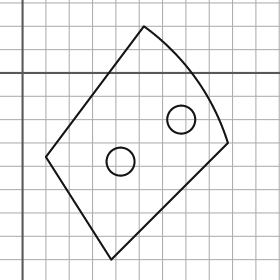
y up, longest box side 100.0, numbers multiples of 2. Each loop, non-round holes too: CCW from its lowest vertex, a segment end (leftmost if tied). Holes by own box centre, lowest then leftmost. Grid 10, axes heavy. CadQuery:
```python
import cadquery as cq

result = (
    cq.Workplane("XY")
    .moveTo(38.0, -80.0)
    .lineTo(88.0, -30.0)
    .threePointArc((74.0, -2.0), (52.0, 20.0))
    .lineTo(10.0, -36.0)
    .close()
    .moveTo(42.0, -38.0)
    .circle(6.0)
    .moveTo(68.0, -20.0)
    .circle(6.0)
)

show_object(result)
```